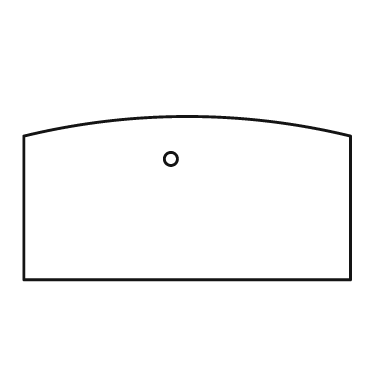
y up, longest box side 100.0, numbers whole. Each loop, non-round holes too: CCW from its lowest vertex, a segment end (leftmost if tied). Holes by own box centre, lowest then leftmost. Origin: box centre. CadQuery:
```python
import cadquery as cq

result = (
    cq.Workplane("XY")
    .moveTo(-50.0, -25.0)
    .lineTo(50.0, -25.0)
    .lineTo(50.0, 19.0)
    .threePointArc((0.0, 25.0), (-50.0, 19.0))
    .close()
    .moveTo(-5.0, 12.0)
    .circle(2.0)
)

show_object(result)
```